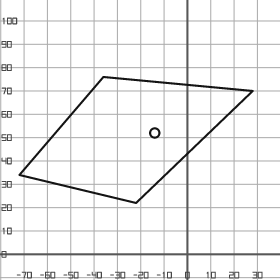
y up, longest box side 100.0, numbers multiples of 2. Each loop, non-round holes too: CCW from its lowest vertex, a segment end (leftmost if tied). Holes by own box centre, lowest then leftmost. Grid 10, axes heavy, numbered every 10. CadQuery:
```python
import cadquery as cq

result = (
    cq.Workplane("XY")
    .moveTo(-22.0, 22.0)
    .lineTo(28.0, 70.0)
    .lineTo(-36.0, 76.0)
    .lineTo(-72.0, 34.0)
    .close()
    .moveTo(-14.0, 52.0)
    .circle(2.0)
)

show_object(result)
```